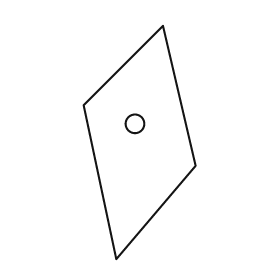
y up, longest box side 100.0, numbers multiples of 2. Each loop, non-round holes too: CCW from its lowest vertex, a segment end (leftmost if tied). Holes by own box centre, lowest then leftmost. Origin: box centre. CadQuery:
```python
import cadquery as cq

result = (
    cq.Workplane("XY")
    .moveTo(-10.0, -50.0)
    .lineTo(24.0, -10.0)
    .lineTo(10.0, 50.0)
    .lineTo(-24.0, 16.0)
    .close()
    .moveTo(-2.0, 8.0)
    .circle(4.0)
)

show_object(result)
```